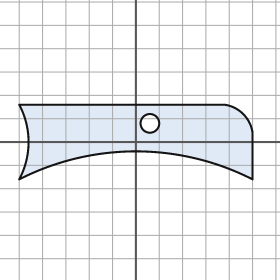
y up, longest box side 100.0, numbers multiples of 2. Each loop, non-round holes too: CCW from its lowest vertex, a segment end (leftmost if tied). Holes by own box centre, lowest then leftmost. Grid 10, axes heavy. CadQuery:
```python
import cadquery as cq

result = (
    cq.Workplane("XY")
    .moveTo(-50.0, -16.0)
    .threePointArc((0.0, -4.0), (50.0, -16.0))
    .lineTo(50.0, 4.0)
    .threePointArc((46.0, 12.0), (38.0, 16.0))
    .lineTo(-50.0, 16.0)
    .threePointArc((-46.0, 0.0), (-50.0, -16.0))
    .close()
    .moveTo(6.0, 8.0)
    .circle(4.0)
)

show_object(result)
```